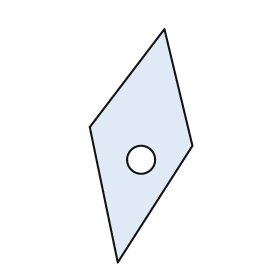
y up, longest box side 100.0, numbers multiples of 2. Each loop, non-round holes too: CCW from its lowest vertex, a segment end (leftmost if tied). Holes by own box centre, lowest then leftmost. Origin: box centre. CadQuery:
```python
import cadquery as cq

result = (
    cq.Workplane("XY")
    .moveTo(-10.0, -50.0)
    .lineTo(22.0, 0.0)
    .lineTo(10.0, 50.0)
    .lineTo(-22.0, 8.0)
    .close()
    .moveTo(0.0, -6.0)
    .circle(6.0)
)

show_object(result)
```